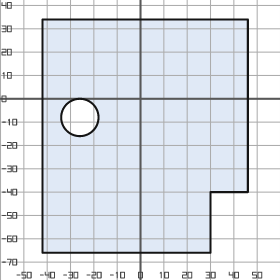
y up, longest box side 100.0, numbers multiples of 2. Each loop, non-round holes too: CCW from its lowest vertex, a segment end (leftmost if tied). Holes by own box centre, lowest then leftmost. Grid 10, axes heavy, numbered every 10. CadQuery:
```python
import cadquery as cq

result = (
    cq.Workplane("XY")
    .moveTo(-42.0, -66.0)
    .lineTo(30.0, -66.0)
    .lineTo(30.0, -40.0)
    .lineTo(46.0, -40.0)
    .lineTo(46.0, 34.0)
    .lineTo(-42.0, 34.0)
    .close()
    .moveTo(-26.0, -8.0)
    .circle(8.0)
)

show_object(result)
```